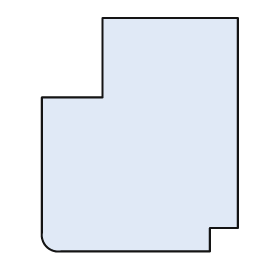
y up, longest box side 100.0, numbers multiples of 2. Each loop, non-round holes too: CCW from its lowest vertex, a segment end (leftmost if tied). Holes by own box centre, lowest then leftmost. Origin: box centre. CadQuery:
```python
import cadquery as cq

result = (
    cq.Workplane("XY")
    .moveTo(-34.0, -50.0)
    .lineTo(30.0, -50.0)
    .lineTo(30.0, -40.0)
    .lineTo(42.0, -40.0)
    .lineTo(42.0, 50.0)
    .lineTo(-16.0, 50.0)
    .lineTo(-16.0, 16.0)
    .lineTo(-42.0, 16.0)
    .lineTo(-42.0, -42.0)
    .threePointArc((-40.0, -48.0), (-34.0, -50.0))
    .close()
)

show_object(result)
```